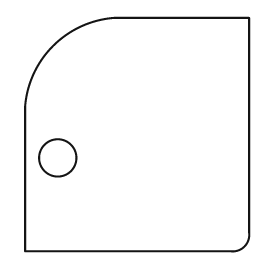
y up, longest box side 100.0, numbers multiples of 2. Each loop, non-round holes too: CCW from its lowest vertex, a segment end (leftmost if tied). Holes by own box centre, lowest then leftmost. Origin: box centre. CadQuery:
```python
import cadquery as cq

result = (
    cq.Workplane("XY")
    .moveTo(-48.0, -50.0)
    .lineTo(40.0, -50.0)
    .threePointArc((46.0, -48.0), (48.0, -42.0))
    .lineTo(48.0, 50.0)
    .lineTo(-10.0, 50.0)
    .threePointArc((-36.0, 38.0), (-48.0, 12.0))
    .close()
    .moveTo(-34.0, -10.0)
    .circle(8.0)
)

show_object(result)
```